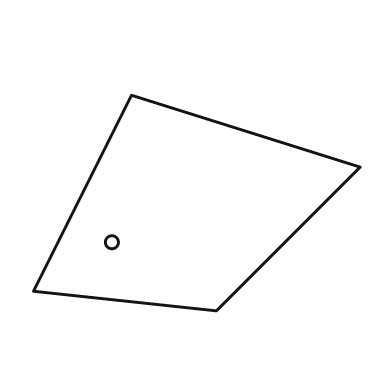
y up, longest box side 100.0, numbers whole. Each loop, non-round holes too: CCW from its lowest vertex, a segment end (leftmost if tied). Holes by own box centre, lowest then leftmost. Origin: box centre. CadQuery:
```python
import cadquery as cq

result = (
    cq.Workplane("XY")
    .moveTo(6.0, -33.0)
    .lineTo(50.0, 11.0)
    .lineTo(-20.0, 33.0)
    .lineTo(-50.0, -27.0)
    .close()
    .moveTo(-26.0, -12.0)
    .circle(2.0)
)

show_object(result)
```